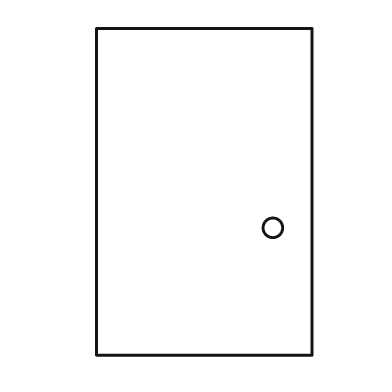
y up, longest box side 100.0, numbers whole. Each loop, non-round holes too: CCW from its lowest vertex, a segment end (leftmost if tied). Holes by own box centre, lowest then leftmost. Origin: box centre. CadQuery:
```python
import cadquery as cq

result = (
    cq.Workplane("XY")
    .moveTo(-33.0, -50.0)
    .lineTo(33.0, -50.0)
    .lineTo(33.0, 50.0)
    .lineTo(-33.0, 50.0)
    .close()
    .moveTo(21.0, -11.0)
    .circle(3.0)
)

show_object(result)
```